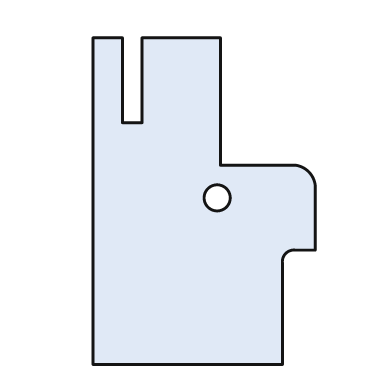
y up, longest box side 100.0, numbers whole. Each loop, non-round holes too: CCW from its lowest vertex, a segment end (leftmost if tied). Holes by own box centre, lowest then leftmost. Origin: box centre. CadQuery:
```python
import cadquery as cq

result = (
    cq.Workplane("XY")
    .moveTo(-34.0, -50.0)
    .lineTo(24.0, -50.0)
    .lineTo(24.0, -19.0)
    .threePointArc((25.0, -16.0), (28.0, -15.0))
    .lineTo(34.0, -15.0)
    .lineTo(34.0, 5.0)
    .threePointArc((32.0, 9.0), (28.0, 11.0))
    .lineTo(5.0, 11.0)
    .lineTo(5.0, 50.0)
    .lineTo(-19.0, 50.0)
    .lineTo(-19.0, 24.0)
    .lineTo(-25.0, 24.0)
    .lineTo(-25.0, 50.0)
    .lineTo(-34.0, 50.0)
    .close()
    .moveTo(4.0, 1.0)
    .circle(4.0)
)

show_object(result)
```